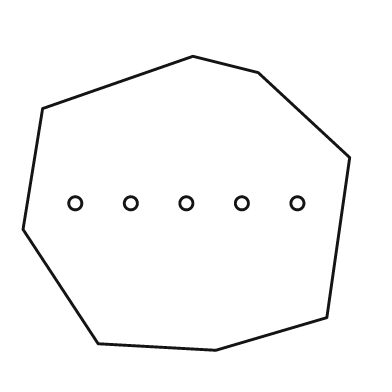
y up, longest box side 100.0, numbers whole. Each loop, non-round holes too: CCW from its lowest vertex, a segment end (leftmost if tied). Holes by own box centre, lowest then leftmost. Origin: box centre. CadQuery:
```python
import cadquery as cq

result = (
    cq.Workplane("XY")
    .moveTo(9.0, -45.0)
    .lineTo(43.0, -35.0)
    .lineTo(50.0, 14.0)
    .lineTo(22.0, 40.0)
    .lineTo(2.0, 45.0)
    .lineTo(-44.0, 29.0)
    .lineTo(-50.0, -8.0)
    .lineTo(-27.0, -43.0)
    .close()
    .moveTo(-34.0, 0.0)
    .circle(2.0)
    .moveTo(-17.0, 0.0)
    .circle(2.0)
    .moveTo(0.0, 0.0)
    .circle(2.0)
    .moveTo(17.0, 0.0)
    .circle(2.0)
    .moveTo(34.0, 0.0)
    .circle(2.0)
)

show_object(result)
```